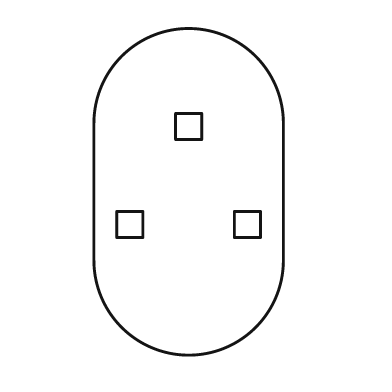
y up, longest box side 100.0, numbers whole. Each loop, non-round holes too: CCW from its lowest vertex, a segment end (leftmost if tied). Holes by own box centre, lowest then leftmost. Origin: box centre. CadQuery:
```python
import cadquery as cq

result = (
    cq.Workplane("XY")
    .moveTo(-29.0, -21.0)
    .threePointArc((0.0, -50.0), (29.0, -21.0))
    .lineTo(29.0, 21.0)
    .threePointArc((0.0, 50.0), (-29.0, 21.0))
    .close()
    .moveTo(-22.0, -14.0)
    .lineTo(-14.0, -14.0)
    .lineTo(-14.0, -6.0)
    .lineTo(-22.0, -6.0)
    .close()
    .moveTo(14.0, -14.0)
    .lineTo(22.0, -14.0)
    .lineTo(22.0, -6.0)
    .lineTo(14.0, -6.0)
    .close()
    .moveTo(-4.0, 16.0)
    .lineTo(4.0, 16.0)
    .lineTo(4.0, 24.0)
    .lineTo(-4.0, 24.0)
    .close()
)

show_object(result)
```